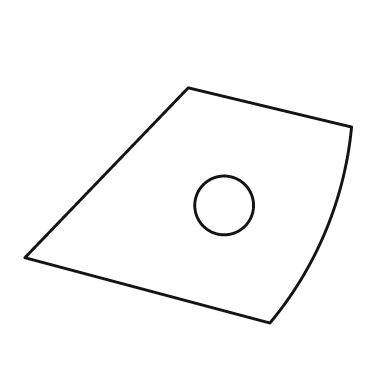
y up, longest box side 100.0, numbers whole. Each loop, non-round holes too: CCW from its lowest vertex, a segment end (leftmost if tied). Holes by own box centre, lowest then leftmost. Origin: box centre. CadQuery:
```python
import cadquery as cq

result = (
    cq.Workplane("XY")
    .moveTo(25.0, -36.0)
    .threePointArc((42.0, -8.0), (50.0, 24.0))
    .lineTo(0.0, 36.0)
    .lineTo(-50.0, -16.0)
    .close()
    .moveTo(11.0, 0.0)
    .circle(9.0)
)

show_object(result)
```